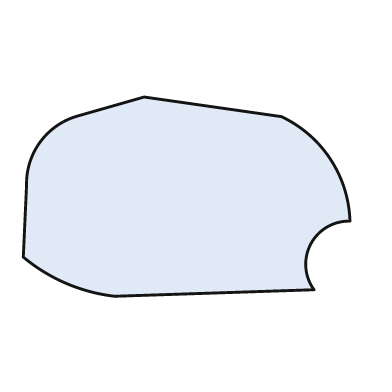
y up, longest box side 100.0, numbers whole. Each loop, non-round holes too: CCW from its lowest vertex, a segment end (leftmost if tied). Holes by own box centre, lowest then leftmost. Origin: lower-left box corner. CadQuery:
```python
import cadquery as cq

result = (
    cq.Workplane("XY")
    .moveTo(28.0, 0.0)
    .lineTo(89.0, 2.0)
    .threePointArc((88.0, 16.0), (100.0, 23.0))
    .threePointArc((94.0, 42.0), (79.0, 55.0))
    .lineTo(37.0, 61.0)
    .lineTo(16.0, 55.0)
    .threePointArc((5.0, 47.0), (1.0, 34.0))
    .lineTo(0.0, 12.0)
    .threePointArc((13.0, 4.0), (28.0, 0.0))
    .close()
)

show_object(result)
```